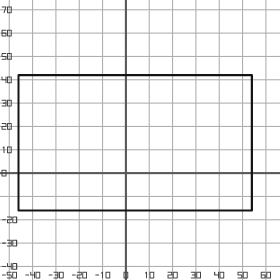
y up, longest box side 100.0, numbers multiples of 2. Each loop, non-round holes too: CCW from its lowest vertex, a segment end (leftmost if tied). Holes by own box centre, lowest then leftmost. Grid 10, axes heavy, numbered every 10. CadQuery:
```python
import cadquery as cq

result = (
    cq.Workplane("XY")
    .moveTo(-46.0, -16.0)
    .lineTo(54.0, -16.0)
    .lineTo(54.0, 42.0)
    .lineTo(-46.0, 42.0)
    .close()
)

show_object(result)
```